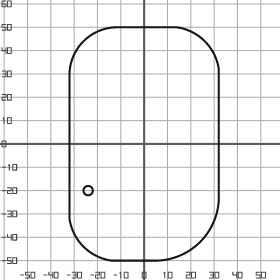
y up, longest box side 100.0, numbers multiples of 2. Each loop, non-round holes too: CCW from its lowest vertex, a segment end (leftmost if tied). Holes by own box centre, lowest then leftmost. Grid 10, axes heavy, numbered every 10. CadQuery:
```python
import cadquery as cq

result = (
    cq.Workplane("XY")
    .moveTo(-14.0, -50.0)
    .lineTo(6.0, -50.0)
    .threePointArc((24.0, -42.0), (32.0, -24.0))
    .lineTo(32.0, 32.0)
    .threePointArc((26.0, 44.0), (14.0, 50.0))
    .lineTo(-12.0, 50.0)
    .threePointArc((-26.0, 44.0), (-32.0, 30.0))
    .lineTo(-32.0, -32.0)
    .threePointArc((-26.0, -44.0), (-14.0, -50.0))
    .close()
    .moveTo(-24.0, -20.0)
    .circle(2.0)
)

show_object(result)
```